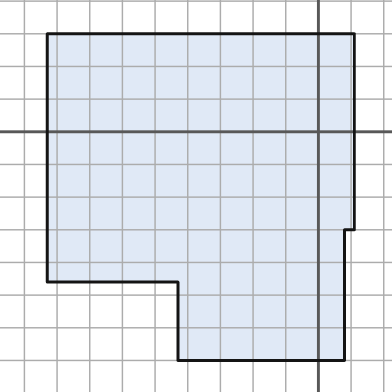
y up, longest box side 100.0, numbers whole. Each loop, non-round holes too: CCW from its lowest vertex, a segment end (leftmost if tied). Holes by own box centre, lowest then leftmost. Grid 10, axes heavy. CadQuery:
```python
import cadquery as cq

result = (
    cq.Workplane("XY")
    .moveTo(-43.0, -70.0)
    .lineTo(8.0, -70.0)
    .lineTo(8.0, -30.0)
    .lineTo(11.0, -30.0)
    .lineTo(11.0, 30.0)
    .lineTo(-83.0, 30.0)
    .lineTo(-83.0, -46.0)
    .lineTo(-43.0, -46.0)
    .close()
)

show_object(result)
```